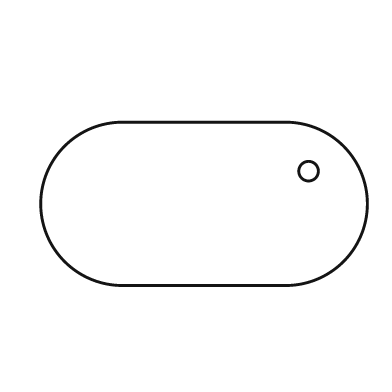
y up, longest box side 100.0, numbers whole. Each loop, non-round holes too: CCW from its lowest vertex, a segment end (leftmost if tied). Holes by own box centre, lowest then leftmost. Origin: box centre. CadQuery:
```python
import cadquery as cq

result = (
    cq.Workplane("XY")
    .moveTo(-25.0, -25.0)
    .lineTo(25.0, -25.0)
    .threePointArc((50.0, 0.0), (25.0, 25.0))
    .lineTo(-25.0, 25.0)
    .threePointArc((-50.0, 0.0), (-25.0, -25.0))
    .close()
    .moveTo(32.0, 10.0)
    .circle(3.0)
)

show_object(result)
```